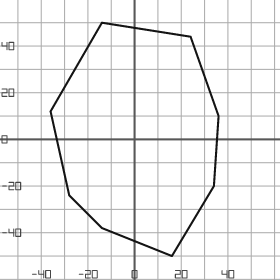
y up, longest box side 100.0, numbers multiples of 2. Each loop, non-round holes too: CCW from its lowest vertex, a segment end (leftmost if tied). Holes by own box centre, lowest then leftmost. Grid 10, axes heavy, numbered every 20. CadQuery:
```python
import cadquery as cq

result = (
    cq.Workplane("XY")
    .moveTo(16.0, -50.0)
    .lineTo(34.0, -20.0)
    .lineTo(36.0, 10.0)
    .lineTo(24.0, 44.0)
    .lineTo(-14.0, 50.0)
    .lineTo(-36.0, 12.0)
    .lineTo(-28.0, -24.0)
    .lineTo(-14.0, -38.0)
    .close()
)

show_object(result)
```